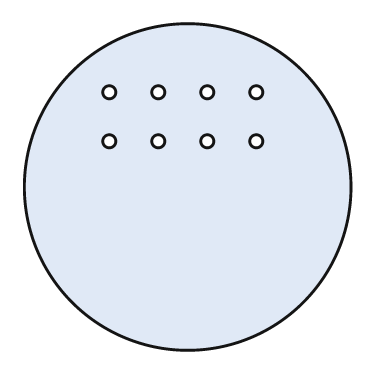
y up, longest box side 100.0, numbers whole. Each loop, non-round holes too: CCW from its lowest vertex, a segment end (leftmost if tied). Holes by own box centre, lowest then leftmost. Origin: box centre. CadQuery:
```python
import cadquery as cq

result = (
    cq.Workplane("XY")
    .moveTo(0.0, 0.0)
    .circle(50.0)
    .moveTo(-24.0, 14.0)
    .circle(2.0)
    .moveTo(-9.0, 14.0)
    .circle(2.0)
    .moveTo(6.0, 14.0)
    .circle(2.0)
    .moveTo(21.0, 14.0)
    .circle(2.0)
    .moveTo(-24.0, 29.0)
    .circle(2.0)
    .moveTo(-9.0, 29.0)
    .circle(2.0)
    .moveTo(6.0, 29.0)
    .circle(2.0)
    .moveTo(21.0, 29.0)
    .circle(2.0)
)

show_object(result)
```